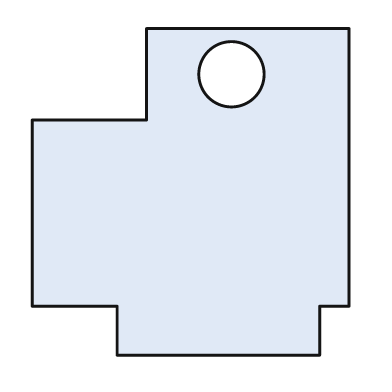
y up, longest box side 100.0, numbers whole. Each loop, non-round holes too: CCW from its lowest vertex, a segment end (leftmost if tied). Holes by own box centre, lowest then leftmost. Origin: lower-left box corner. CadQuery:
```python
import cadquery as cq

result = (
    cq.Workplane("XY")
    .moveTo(26.0, 0.0)
    .lineTo(88.0, 0.0)
    .lineTo(88.0, 15.0)
    .lineTo(97.0, 15.0)
    .lineTo(97.0, 100.0)
    .lineTo(35.0, 100.0)
    .lineTo(35.0, 72.0)
    .lineTo(0.0, 72.0)
    .lineTo(0.0, 15.0)
    .lineTo(26.0, 15.0)
    .close()
    .moveTo(61.0, 86.0)
    .circle(10.0)
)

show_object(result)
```